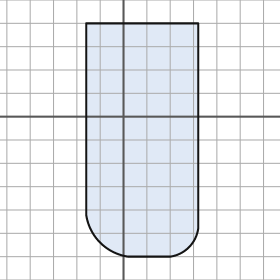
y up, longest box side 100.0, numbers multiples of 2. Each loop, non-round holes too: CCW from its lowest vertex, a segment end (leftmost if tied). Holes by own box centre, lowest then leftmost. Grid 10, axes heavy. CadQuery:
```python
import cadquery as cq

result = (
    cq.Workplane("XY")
    .moveTo(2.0, -60.0)
    .lineTo(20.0, -60.0)
    .threePointArc((28.0, -56.0), (32.0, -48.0))
    .lineTo(32.0, 40.0)
    .lineTo(-16.0, 40.0)
    .lineTo(-16.0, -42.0)
    .threePointArc((-10.0, -54.0), (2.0, -60.0))
    .close()
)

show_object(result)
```